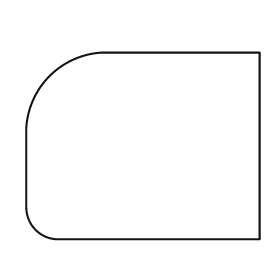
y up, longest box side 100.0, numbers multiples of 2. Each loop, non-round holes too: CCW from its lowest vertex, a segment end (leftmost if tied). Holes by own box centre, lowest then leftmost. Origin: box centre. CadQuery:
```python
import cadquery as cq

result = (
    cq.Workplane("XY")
    .moveTo(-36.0, -40.0)
    .lineTo(50.0, -40.0)
    .lineTo(50.0, 40.0)
    .lineTo(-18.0, 40.0)
    .threePointArc((-40.0, 30.0), (-50.0, 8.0))
    .lineTo(-50.0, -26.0)
    .threePointArc((-46.0, -36.0), (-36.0, -40.0))
    .close()
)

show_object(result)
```